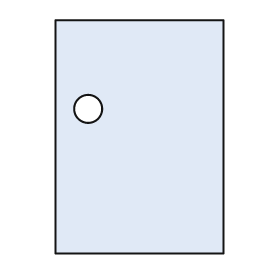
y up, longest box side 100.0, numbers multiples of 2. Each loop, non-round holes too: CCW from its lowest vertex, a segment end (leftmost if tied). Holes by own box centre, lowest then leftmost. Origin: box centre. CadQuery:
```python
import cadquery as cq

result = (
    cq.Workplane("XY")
    .moveTo(-36.0, -50.0)
    .lineTo(36.0, -50.0)
    .lineTo(36.0, 50.0)
    .lineTo(-36.0, 50.0)
    .close()
    .moveTo(-22.0, 12.0)
    .circle(6.0)
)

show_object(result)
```